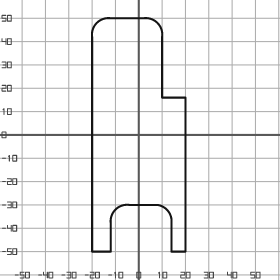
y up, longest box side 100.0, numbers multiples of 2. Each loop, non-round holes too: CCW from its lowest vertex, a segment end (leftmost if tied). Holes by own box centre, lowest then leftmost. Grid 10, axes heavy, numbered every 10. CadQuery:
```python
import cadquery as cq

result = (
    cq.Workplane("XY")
    .moveTo(-20.0, -50.0)
    .lineTo(-12.0, -50.0)
    .lineTo(-12.0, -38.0)
    .threePointArc((-10.0, -32.0), (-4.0, -30.0))
    .lineTo(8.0, -30.0)
    .threePointArc((12.0, -32.0), (14.0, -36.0))
    .lineTo(14.0, -50.0)
    .lineTo(20.0, -50.0)
    .lineTo(20.0, 16.0)
    .lineTo(10.0, 16.0)
    .lineTo(10.0, 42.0)
    .threePointArc((8.0, 48.0), (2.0, 50.0))
    .lineTo(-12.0, 50.0)
    .threePointArc((-18.0, 48.0), (-20.0, 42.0))
    .close()
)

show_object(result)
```